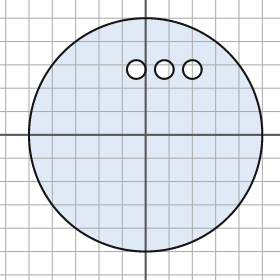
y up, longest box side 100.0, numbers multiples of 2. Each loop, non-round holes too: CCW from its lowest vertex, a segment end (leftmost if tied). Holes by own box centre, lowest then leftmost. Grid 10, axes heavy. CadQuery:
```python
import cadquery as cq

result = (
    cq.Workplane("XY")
    .moveTo(0.0, 0.0)
    .circle(50.0)
    .moveTo(-4.0, 28.0)
    .circle(4.0)
    .moveTo(8.0, 28.0)
    .circle(4.0)
    .moveTo(20.0, 28.0)
    .circle(4.0)
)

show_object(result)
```